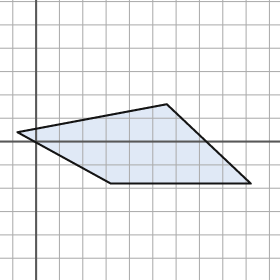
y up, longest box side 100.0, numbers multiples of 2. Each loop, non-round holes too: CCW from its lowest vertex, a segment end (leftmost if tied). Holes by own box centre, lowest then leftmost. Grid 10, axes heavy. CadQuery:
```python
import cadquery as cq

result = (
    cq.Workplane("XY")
    .moveTo(32.0, -18.0)
    .lineTo(92.0, -18.0)
    .lineTo(56.0, 16.0)
    .lineTo(-8.0, 4.0)
    .close()
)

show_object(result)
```